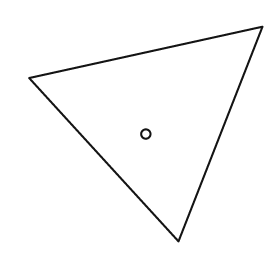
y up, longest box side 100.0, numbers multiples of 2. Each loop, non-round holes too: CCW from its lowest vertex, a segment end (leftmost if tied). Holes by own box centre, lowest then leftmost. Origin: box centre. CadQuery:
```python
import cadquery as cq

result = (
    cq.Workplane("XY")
    .moveTo(14.0, -46.0)
    .lineTo(50.0, 46.0)
    .lineTo(-50.0, 24.0)
    .close()
    .moveTo(0.0, 0.0)
    .circle(2.0)
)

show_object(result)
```